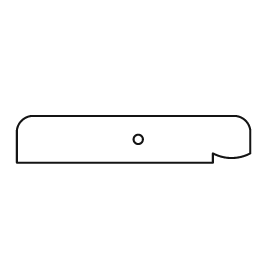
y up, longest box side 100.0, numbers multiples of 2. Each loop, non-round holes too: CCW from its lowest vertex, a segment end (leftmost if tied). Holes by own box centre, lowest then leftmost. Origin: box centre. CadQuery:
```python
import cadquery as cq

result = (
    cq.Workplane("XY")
    .moveTo(-50.0, -10.0)
    .lineTo(34.0, -10.0)
    .lineTo(34.0, -6.0)
    .threePointArc((42.0, -8.0), (50.0, -6.0))
    .lineTo(50.0, 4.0)
    .threePointArc((48.0, 8.0), (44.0, 10.0))
    .lineTo(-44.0, 10.0)
    .threePointArc((-48.0, 8.0), (-50.0, 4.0))
    .close()
    .moveTo(2.0, 0.0)
    .circle(2.0)
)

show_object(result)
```